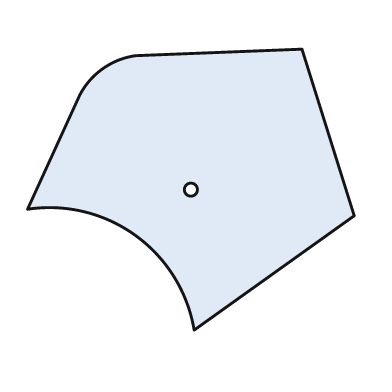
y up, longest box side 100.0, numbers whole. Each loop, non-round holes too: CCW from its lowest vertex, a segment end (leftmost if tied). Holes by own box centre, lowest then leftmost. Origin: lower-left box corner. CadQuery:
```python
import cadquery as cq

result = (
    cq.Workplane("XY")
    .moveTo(51.0, 0.0)
    .lineTo(100.0, 35.0)
    .lineTo(84.0, 86.0)
    .lineTo(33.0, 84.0)
    .threePointArc((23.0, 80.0), (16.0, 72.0))
    .lineTo(0.0, 37.0)
    .threePointArc((33.0, 29.0), (51.0, 0.0))
    .close()
    .moveTo(50.0, 43.0)
    .circle(2.0)
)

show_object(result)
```